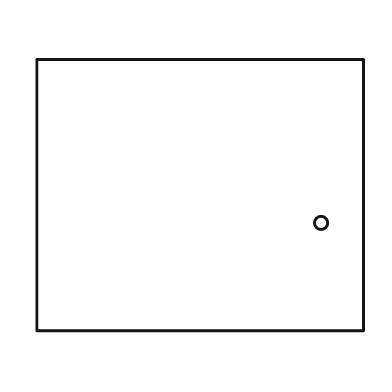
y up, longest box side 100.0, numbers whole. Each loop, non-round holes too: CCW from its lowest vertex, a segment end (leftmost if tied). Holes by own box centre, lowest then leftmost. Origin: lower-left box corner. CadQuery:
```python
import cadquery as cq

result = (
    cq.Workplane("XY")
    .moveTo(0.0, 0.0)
    .lineTo(100.0, 0.0)
    .lineTo(100.0, 83.0)
    .lineTo(0.0, 83.0)
    .close()
    .moveTo(87.0, 33.0)
    .circle(2.0)
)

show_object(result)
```